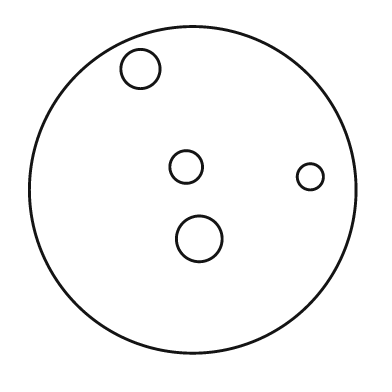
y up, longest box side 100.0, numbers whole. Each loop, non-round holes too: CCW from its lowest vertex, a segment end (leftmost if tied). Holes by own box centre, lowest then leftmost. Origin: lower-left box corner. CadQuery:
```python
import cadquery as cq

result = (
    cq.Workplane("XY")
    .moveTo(50.0, 50.0)
    .circle(50.0)
    .moveTo(52.0, 35.0)
    .circle(7.0)
    .moveTo(86.0, 54.0)
    .circle(4.0)
    .moveTo(48.0, 57.0)
    .circle(5.0)
    .moveTo(34.0, 87.0)
    .circle(6.0)
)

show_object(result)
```